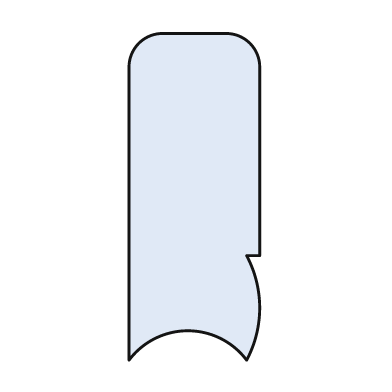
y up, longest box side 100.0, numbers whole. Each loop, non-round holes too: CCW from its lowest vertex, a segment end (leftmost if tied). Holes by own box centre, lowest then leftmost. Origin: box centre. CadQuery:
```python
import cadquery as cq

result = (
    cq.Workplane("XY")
    .moveTo(-20.0, -50.0)
    .threePointArc((-2.0, -41.0), (16.0, -50.0))
    .threePointArc((20.0, -34.0), (16.0, -18.0))
    .lineTo(20.0, -18.0)
    .lineTo(20.0, 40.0)
    .threePointArc((17.0, 47.0), (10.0, 50.0))
    .lineTo(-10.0, 50.0)
    .threePointArc((-17.0, 47.0), (-20.0, 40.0))
    .close()
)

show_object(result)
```